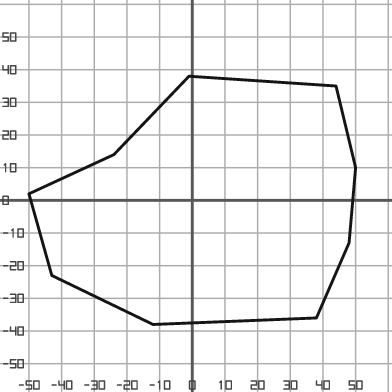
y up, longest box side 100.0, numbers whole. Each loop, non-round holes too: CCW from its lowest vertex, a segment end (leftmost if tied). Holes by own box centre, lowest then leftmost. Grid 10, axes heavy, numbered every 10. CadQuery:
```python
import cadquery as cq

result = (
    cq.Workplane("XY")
    .moveTo(-12.0, -38.0)
    .lineTo(38.0, -36.0)
    .lineTo(48.0, -13.0)
    .lineTo(50.0, 10.0)
    .lineTo(44.0, 35.0)
    .lineTo(-1.0, 38.0)
    .lineTo(-24.0, 14.0)
    .lineTo(-50.0, 2.0)
    .lineTo(-43.0, -23.0)
    .close()
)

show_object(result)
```